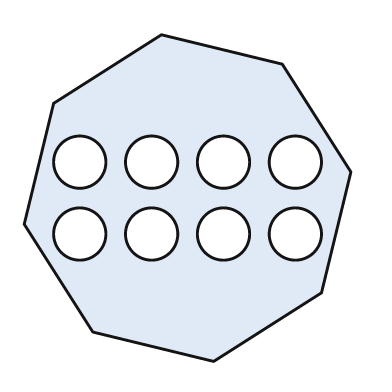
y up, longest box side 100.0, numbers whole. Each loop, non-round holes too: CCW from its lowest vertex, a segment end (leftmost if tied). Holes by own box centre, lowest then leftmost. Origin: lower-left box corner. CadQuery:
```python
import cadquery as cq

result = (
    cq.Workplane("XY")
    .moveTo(58.0, 0.0)
    .lineTo(91.0, 21.0)
    .lineTo(100.0, 58.0)
    .lineTo(79.0, 91.0)
    .lineTo(42.0, 100.0)
    .lineTo(9.0, 79.0)
    .lineTo(0.0, 42.0)
    .lineTo(21.0, 9.0)
    .close()
    .moveTo(17.0, 39.0)
    .circle(8.0)
    .moveTo(39.0, 39.0)
    .circle(8.0)
    .moveTo(61.0, 39.0)
    .circle(8.0)
    .moveTo(83.0, 39.0)
    .circle(8.0)
    .moveTo(17.0, 61.0)
    .circle(8.0)
    .moveTo(39.0, 61.0)
    .circle(8.0)
    .moveTo(61.0, 61.0)
    .circle(8.0)
    .moveTo(83.0, 61.0)
    .circle(8.0)
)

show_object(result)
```